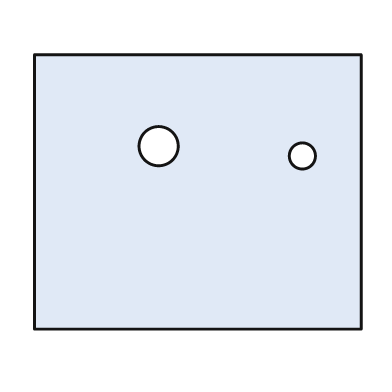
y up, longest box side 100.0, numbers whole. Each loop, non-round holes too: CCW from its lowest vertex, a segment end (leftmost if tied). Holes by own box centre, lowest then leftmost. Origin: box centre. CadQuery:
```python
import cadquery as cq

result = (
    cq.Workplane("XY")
    .moveTo(-50.0, -42.0)
    .lineTo(50.0, -42.0)
    .lineTo(50.0, 42.0)
    .lineTo(-50.0, 42.0)
    .close()
    .moveTo(32.0, 11.0)
    .circle(4.0)
    .moveTo(-12.0, 14.0)
    .circle(6.0)
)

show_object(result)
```